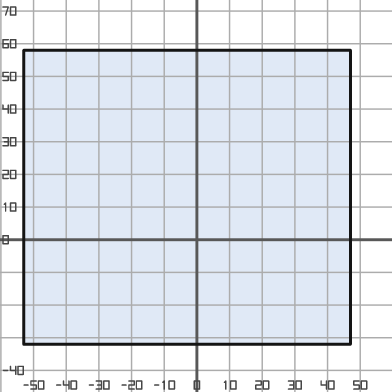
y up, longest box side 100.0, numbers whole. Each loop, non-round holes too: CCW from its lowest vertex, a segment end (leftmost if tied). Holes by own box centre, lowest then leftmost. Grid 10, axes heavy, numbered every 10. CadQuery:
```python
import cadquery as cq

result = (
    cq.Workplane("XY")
    .moveTo(-53.0, -32.0)
    .lineTo(47.0, -32.0)
    .lineTo(47.0, 58.0)
    .lineTo(-53.0, 58.0)
    .close()
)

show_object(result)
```